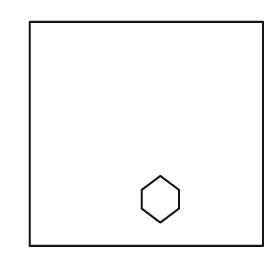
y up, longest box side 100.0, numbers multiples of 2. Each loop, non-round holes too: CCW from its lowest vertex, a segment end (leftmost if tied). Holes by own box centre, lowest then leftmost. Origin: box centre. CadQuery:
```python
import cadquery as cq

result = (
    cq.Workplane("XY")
    .moveTo(-50.0, -48.0)
    .lineTo(50.0, -48.0)
    .lineTo(50.0, 48.0)
    .lineTo(-50.0, 48.0)
    .close()
    .moveTo(6.0, -38.0)
    .lineTo(14.0, -32.0)
    .lineTo(14.0, -24.0)
    .lineTo(6.0, -18.0)
    .lineTo(-2.0, -24.0)
    .lineTo(-2.0, -32.0)
    .close()
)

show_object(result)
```